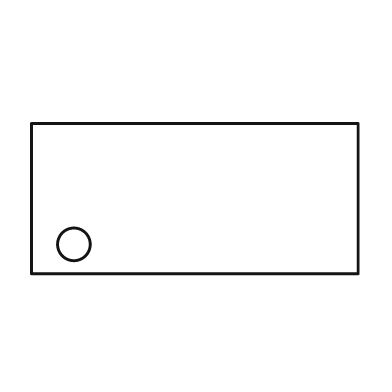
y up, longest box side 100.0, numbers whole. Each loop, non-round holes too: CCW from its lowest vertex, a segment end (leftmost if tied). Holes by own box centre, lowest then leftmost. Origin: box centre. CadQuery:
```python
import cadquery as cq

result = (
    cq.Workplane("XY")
    .moveTo(-50.0, -23.0)
    .lineTo(50.0, -23.0)
    .lineTo(50.0, 23.0)
    .lineTo(-50.0, 23.0)
    .close()
    .moveTo(-37.0, -14.0)
    .circle(5.0)
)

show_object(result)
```